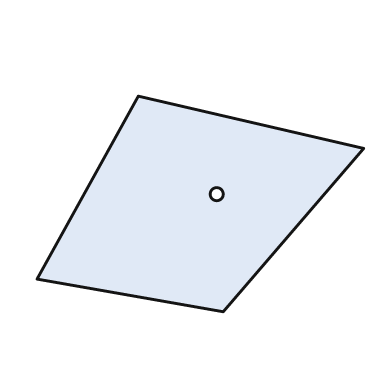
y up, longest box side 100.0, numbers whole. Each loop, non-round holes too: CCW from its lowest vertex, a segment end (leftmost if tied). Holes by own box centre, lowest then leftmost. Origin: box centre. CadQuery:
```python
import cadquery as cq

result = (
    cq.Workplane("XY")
    .moveTo(7.0, -33.0)
    .lineTo(50.0, 17.0)
    .lineTo(-19.0, 33.0)
    .lineTo(-50.0, -23.0)
    .close()
    .moveTo(5.0, 3.0)
    .circle(2.0)
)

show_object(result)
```